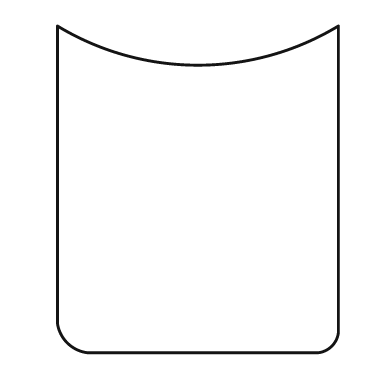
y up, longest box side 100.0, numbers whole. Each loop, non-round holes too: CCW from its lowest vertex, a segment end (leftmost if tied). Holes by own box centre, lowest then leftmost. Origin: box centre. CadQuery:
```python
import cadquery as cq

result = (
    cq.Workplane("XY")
    .moveTo(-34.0, -50.0)
    .lineTo(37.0, -50.0)
    .threePointArc((41.0, -48.0), (43.0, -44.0))
    .lineTo(43.0, 50.0)
    .threePointArc((0.0, 38.0), (-43.0, 50.0))
    .lineTo(-43.0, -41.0)
    .threePointArc((-40.0, -47.0), (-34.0, -50.0))
    .close()
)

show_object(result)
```